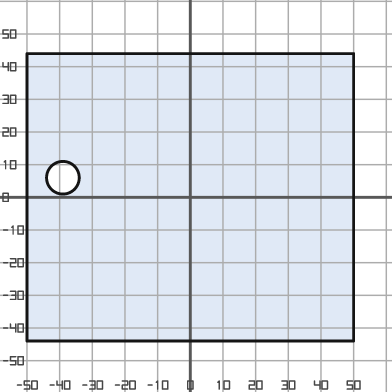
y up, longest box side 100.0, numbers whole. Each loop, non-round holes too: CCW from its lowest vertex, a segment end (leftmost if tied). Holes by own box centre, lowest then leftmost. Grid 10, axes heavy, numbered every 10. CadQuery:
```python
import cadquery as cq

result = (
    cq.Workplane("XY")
    .moveTo(-50.0, -44.0)
    .lineTo(50.0, -44.0)
    .lineTo(50.0, 44.0)
    .lineTo(-50.0, 44.0)
    .close()
    .moveTo(-39.0, 6.0)
    .circle(5.0)
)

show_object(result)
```